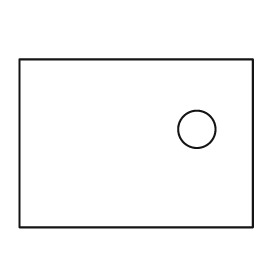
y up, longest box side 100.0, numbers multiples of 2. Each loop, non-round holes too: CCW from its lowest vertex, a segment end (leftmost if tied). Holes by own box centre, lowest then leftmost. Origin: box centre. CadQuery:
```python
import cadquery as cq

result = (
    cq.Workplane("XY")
    .moveTo(-50.0, -36.0)
    .lineTo(50.0, -36.0)
    .lineTo(50.0, 36.0)
    .lineTo(-50.0, 36.0)
    .close()
    .moveTo(26.0, 6.0)
    .circle(8.0)
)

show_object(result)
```